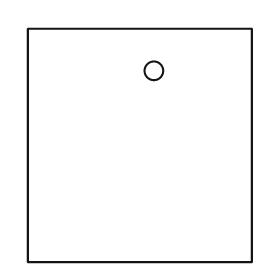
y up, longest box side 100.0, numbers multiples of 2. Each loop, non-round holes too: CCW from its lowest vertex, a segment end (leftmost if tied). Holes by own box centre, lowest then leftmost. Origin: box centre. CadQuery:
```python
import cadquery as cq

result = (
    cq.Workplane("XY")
    .moveTo(-48.0, -50.0)
    .lineTo(48.0, -50.0)
    .lineTo(48.0, 50.0)
    .lineTo(-48.0, 50.0)
    .close()
    .moveTo(6.0, 32.0)
    .circle(4.0)
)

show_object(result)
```